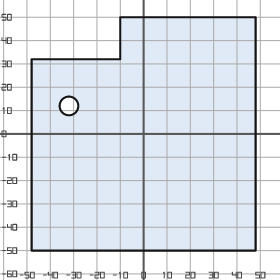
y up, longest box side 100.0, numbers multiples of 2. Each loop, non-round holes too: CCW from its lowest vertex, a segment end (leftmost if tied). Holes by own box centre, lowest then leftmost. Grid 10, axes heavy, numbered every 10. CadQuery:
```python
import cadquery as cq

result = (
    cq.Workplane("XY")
    .moveTo(-48.0, -50.0)
    .lineTo(48.0, -50.0)
    .lineTo(48.0, 50.0)
    .lineTo(-10.0, 50.0)
    .lineTo(-10.0, 32.0)
    .lineTo(-48.0, 32.0)
    .close()
    .moveTo(-32.0, 12.0)
    .circle(4.0)
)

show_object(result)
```